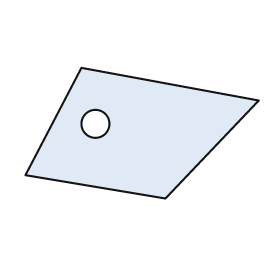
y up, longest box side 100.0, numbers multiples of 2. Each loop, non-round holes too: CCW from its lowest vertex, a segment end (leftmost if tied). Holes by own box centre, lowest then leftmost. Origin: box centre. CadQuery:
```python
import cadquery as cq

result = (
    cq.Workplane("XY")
    .moveTo(10.0, -28.0)
    .lineTo(50.0, 14.0)
    .lineTo(-26.0, 28.0)
    .lineTo(-50.0, -18.0)
    .close()
    .moveTo(-20.0, 4.0)
    .circle(6.0)
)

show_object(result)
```